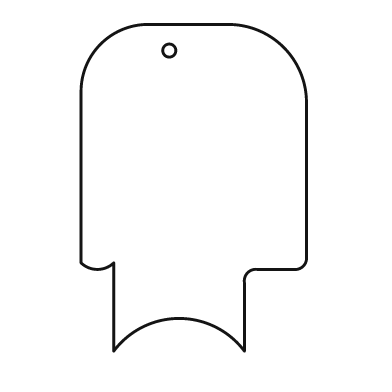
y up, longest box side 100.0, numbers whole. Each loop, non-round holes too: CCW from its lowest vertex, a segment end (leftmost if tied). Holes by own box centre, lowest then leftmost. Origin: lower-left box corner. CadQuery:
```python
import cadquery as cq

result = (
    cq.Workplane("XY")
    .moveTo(10.0, 0.0)
    .threePointArc((30.0, 10.0), (50.0, 0.0))
    .lineTo(50.0, 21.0)
    .threePointArc((51.0, 24.0), (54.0, 25.0))
    .lineTo(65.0, 25.0)
    .threePointArc((68.0, 26.0), (69.0, 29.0))
    .lineTo(69.0, 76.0)
    .threePointArc((62.0, 93.0), (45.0, 100.0))
    .lineTo(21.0, 100.0)
    .threePointArc((6.0, 94.0), (0.0, 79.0))
    .lineTo(0.0, 27.0)
    .threePointArc((5.0, 25.0), (10.0, 27.0))
    .close()
    .moveTo(27.0, 92.0)
    .circle(2.0)
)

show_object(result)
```